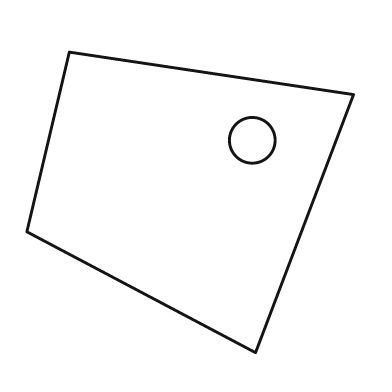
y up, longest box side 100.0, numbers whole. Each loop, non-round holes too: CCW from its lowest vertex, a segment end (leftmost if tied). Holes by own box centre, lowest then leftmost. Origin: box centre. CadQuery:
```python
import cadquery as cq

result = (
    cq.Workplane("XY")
    .moveTo(20.0, -46.0)
    .lineTo(50.0, 33.0)
    .lineTo(-37.0, 46.0)
    .lineTo(-50.0, -9.0)
    .close()
    .moveTo(19.0, 19.0)
    .circle(7.0)
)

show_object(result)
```